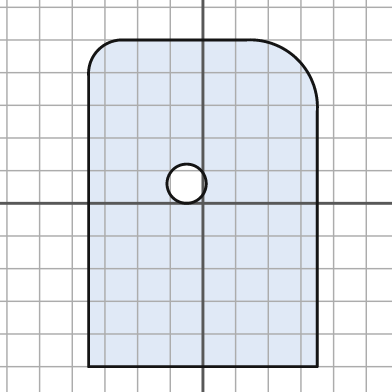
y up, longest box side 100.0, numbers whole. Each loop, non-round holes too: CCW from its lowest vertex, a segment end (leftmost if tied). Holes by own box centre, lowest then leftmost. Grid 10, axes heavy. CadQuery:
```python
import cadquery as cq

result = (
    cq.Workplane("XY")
    .moveTo(-35.0, -50.0)
    .lineTo(35.0, -50.0)
    .lineTo(35.0, 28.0)
    .threePointArc((29.0, 44.0), (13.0, 50.0))
    .lineTo(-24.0, 50.0)
    .threePointArc((-32.0, 47.0), (-35.0, 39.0))
    .close()
    .moveTo(-5.0, 6.0)
    .circle(6.0)
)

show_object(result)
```